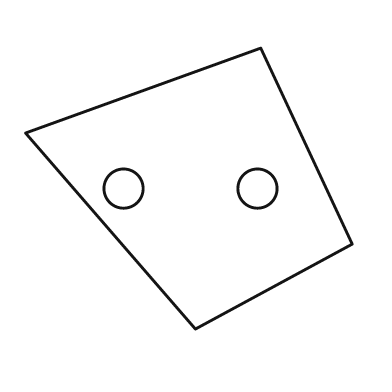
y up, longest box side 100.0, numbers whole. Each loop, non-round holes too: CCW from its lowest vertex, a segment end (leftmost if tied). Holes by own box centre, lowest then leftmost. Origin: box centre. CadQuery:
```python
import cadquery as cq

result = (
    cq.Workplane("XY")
    .moveTo(2.0, -43.0)
    .lineTo(50.0, -17.0)
    .lineTo(22.0, 43.0)
    .lineTo(-50.0, 17.0)
    .close()
    .moveTo(-20.0, 0.0)
    .circle(6.0)
    .moveTo(21.0, 0.0)
    .circle(6.0)
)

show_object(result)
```